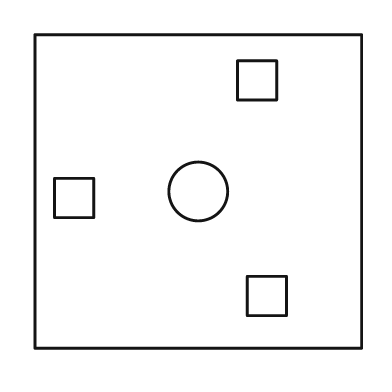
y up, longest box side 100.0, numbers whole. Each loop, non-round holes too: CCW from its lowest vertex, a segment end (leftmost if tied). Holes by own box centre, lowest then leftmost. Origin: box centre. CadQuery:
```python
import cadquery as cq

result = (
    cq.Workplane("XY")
    .moveTo(-50.0, -48.0)
    .lineTo(50.0, -48.0)
    .lineTo(50.0, 48.0)
    .lineTo(-50.0, 48.0)
    .close()
    .moveTo(15.0, -38.0)
    .lineTo(27.0, -38.0)
    .lineTo(27.0, -26.0)
    .lineTo(15.0, -26.0)
    .close()
    .moveTo(-44.0, -8.0)
    .lineTo(-32.0, -8.0)
    .lineTo(-32.0, 4.0)
    .lineTo(-44.0, 4.0)
    .close()
    .moveTo(0.0, 0.0)
    .circle(9.0)
    .moveTo(12.0, 28.0)
    .lineTo(24.0, 28.0)
    .lineTo(24.0, 40.0)
    .lineTo(12.0, 40.0)
    .close()
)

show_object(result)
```